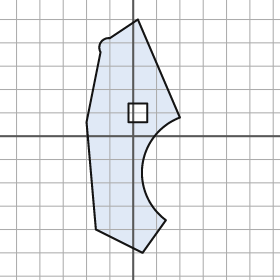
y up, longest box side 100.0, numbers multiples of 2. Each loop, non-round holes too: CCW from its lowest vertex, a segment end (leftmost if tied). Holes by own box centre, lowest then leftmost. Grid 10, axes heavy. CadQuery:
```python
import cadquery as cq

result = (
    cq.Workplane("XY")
    .moveTo(4.0, -50.0)
    .lineTo(14.0, -36.0)
    .threePointArc((4.0, -12.0), (20.0, 8.0))
    .lineTo(2.0, 50.0)
    .lineTo(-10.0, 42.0)
    .threePointArc((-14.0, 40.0), (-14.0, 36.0))
    .lineTo(-20.0, 6.0)
    .lineTo(-16.0, -40.0)
    .close()
    .moveTo(-2.0, 6.0)
    .lineTo(6.0, 6.0)
    .lineTo(6.0, 14.0)
    .lineTo(-2.0, 14.0)
    .close()
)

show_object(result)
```